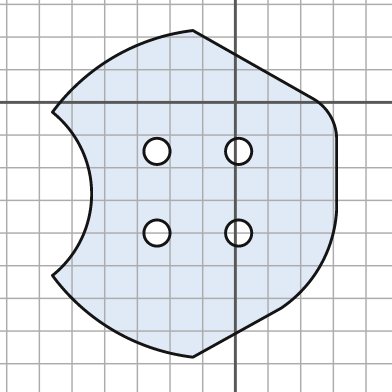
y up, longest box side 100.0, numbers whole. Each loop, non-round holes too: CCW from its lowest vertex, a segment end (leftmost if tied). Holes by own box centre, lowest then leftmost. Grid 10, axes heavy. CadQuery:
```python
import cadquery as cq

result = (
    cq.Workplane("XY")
    .moveTo(-13.0, -78.0)
    .lineTo(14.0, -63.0)
    .threePointArc((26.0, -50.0), (31.0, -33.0))
    .lineTo(31.0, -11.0)
    .threePointArc((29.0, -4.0), (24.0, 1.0))
    .lineTo(-13.0, 22.0)
    .threePointArc((-37.0, 14.0), (-56.0, -3.0))
    .threePointArc((-44.0, -28.0), (-56.0, -53.0))
    .threePointArc((-37.0, -70.0), (-13.0, -78.0))
    .close()
    .moveTo(-24.0, -40.0)
    .circle(4.0)
    .moveTo(1.0, -40.0)
    .circle(4.0)
    .moveTo(-24.0, -15.0)
    .circle(4.0)
    .moveTo(1.0, -15.0)
    .circle(4.0)
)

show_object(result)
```